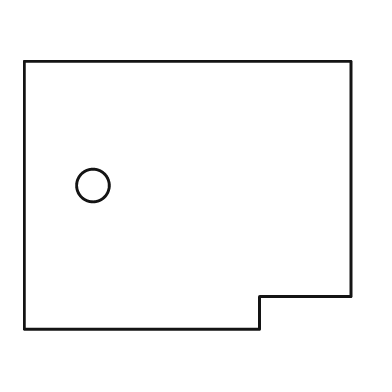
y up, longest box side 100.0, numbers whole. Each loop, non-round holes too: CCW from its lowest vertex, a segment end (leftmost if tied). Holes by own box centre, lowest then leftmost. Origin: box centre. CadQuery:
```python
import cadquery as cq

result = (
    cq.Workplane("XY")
    .moveTo(-50.0, -41.0)
    .lineTo(22.0, -41.0)
    .lineTo(22.0, -31.0)
    .lineTo(50.0, -31.0)
    .lineTo(50.0, 41.0)
    .lineTo(-50.0, 41.0)
    .close()
    .moveTo(-29.0, 3.0)
    .circle(5.0)
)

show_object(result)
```